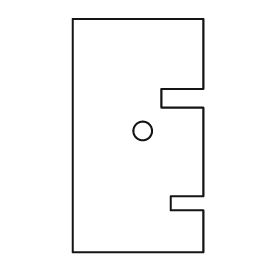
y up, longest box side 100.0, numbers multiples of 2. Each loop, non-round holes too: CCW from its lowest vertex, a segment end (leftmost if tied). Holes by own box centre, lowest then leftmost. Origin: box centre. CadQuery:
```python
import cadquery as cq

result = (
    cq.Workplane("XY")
    .moveTo(-28.0, -50.0)
    .lineTo(28.0, -50.0)
    .lineTo(28.0, -32.0)
    .lineTo(14.0, -32.0)
    .lineTo(14.0, -26.0)
    .lineTo(28.0, -26.0)
    .lineTo(28.0, 12.0)
    .lineTo(10.0, 12.0)
    .lineTo(10.0, 20.0)
    .lineTo(28.0, 20.0)
    .lineTo(28.0, 50.0)
    .lineTo(-28.0, 50.0)
    .close()
    .moveTo(2.0, 2.0)
    .circle(4.0)
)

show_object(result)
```